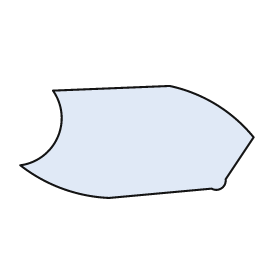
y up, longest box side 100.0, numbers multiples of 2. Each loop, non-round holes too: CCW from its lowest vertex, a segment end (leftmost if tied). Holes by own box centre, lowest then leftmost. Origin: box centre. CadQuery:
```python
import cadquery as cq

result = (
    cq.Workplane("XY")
    .moveTo(-12.0, -24.0)
    .lineTo(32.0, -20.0)
    .threePointArc((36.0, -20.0), (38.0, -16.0))
    .lineTo(50.0, 2.0)
    .threePointArc((34.0, 16.0), (14.0, 24.0))
    .lineTo(-36.0, 22.0)
    .threePointArc((-34.0, 2.0), (-50.0, -10.0))
    .threePointArc((-32.0, -20.0), (-12.0, -24.0))
    .close()
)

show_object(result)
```